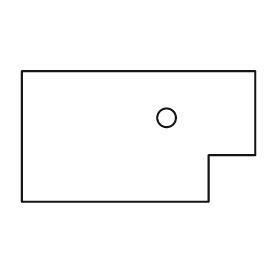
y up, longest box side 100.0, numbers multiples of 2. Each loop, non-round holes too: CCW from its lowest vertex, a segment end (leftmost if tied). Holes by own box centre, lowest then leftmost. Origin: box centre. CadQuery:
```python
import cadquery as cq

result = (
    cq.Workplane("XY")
    .moveTo(-50.0, -28.0)
    .lineTo(30.0, -28.0)
    .lineTo(30.0, -8.0)
    .lineTo(50.0, -8.0)
    .lineTo(50.0, 28.0)
    .lineTo(-50.0, 28.0)
    .close()
    .moveTo(12.0, 8.0)
    .circle(4.0)
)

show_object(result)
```